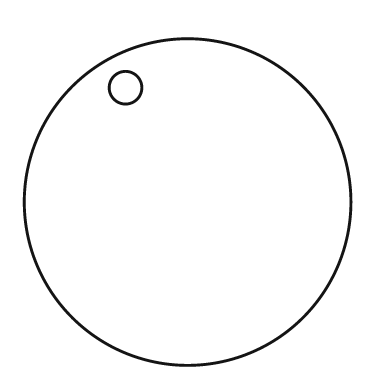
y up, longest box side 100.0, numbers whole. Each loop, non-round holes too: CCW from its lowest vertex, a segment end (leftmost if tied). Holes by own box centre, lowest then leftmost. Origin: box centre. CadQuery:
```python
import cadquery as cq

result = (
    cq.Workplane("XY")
    .moveTo(0.0, 0.0)
    .circle(50.0)
    .moveTo(-19.0, 35.0)
    .circle(5.0)
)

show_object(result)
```